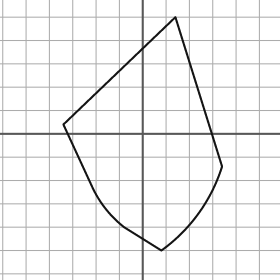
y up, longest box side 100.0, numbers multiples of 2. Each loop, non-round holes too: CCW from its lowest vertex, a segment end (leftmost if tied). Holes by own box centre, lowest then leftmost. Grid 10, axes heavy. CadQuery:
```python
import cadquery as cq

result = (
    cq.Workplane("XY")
    .moveTo(8.0, -50.0)
    .threePointArc((24.0, -34.0), (34.0, -14.0))
    .lineTo(14.0, 50.0)
    .lineTo(-34.0, 4.0)
    .lineTo(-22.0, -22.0)
    .threePointArc((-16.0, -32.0), (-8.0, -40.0))
    .close()
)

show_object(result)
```